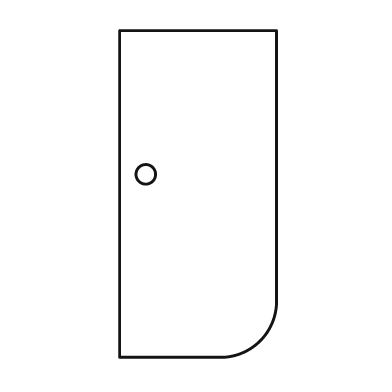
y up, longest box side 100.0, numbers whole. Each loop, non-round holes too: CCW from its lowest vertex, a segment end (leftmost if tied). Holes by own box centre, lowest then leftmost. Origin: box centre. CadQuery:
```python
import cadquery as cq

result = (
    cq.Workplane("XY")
    .moveTo(-24.0, -50.0)
    .lineTo(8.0, -50.0)
    .threePointArc((19.0, -45.0), (24.0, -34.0))
    .lineTo(24.0, 50.0)
    .lineTo(-24.0, 50.0)
    .close()
    .moveTo(-16.0, 6.0)
    .circle(3.0)
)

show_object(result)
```